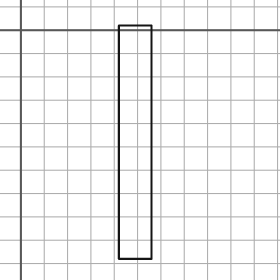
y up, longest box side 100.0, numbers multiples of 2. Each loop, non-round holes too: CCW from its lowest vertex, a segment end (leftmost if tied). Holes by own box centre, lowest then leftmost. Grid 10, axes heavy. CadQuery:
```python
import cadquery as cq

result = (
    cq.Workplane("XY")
    .moveTo(42.0, -98.0)
    .lineTo(56.0, -98.0)
    .lineTo(56.0, 2.0)
    .lineTo(42.0, 2.0)
    .close()
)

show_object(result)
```